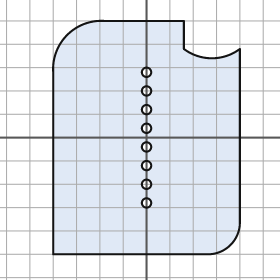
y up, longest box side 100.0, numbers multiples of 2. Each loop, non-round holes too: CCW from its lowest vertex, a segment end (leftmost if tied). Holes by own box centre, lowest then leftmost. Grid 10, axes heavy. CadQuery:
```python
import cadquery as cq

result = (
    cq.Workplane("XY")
    .moveTo(-40.0, -50.0)
    .lineTo(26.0, -50.0)
    .threePointArc((36.0, -46.0), (40.0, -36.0))
    .lineTo(40.0, 38.0)
    .threePointArc((28.0, 34.0), (16.0, 38.0))
    .lineTo(16.0, 50.0)
    .lineTo(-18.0, 50.0)
    .threePointArc((-34.0, 44.0), (-40.0, 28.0))
    .close()
    .moveTo(0.0, -28.0)
    .circle(2.0)
    .moveTo(0.0, -20.0)
    .circle(2.0)
    .moveTo(0.0, -12.0)
    .circle(2.0)
    .moveTo(0.0, -4.0)
    .circle(2.0)
    .moveTo(0.0, 4.0)
    .circle(2.0)
    .moveTo(0.0, 12.0)
    .circle(2.0)
    .moveTo(0.0, 20.0)
    .circle(2.0)
    .moveTo(0.0, 28.0)
    .circle(2.0)
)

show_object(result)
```